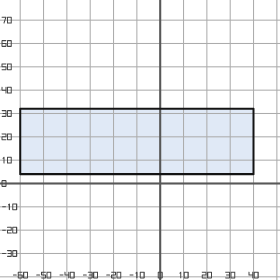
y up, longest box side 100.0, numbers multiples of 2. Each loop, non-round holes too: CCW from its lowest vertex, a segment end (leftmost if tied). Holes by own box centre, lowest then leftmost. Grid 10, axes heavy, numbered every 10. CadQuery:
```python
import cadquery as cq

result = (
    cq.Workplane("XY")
    .moveTo(-60.0, 4.0)
    .lineTo(40.0, 4.0)
    .lineTo(40.0, 32.0)
    .lineTo(-60.0, 32.0)
    .close()
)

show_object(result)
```